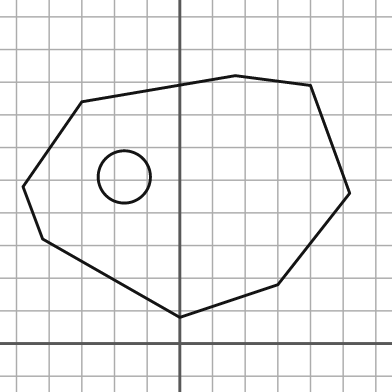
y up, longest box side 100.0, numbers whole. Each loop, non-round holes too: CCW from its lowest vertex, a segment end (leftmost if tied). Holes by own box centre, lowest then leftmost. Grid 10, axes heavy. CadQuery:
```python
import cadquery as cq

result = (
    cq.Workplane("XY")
    .moveTo(0.0, 8.0)
    .lineTo(30.0, 18.0)
    .lineTo(52.0, 46.0)
    .lineTo(40.0, 79.0)
    .lineTo(17.0, 82.0)
    .lineTo(-30.0, 74.0)
    .lineTo(-48.0, 48.0)
    .lineTo(-42.0, 32.0)
    .close()
    .moveTo(-17.0, 51.0)
    .circle(8.0)
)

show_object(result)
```